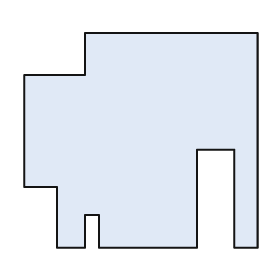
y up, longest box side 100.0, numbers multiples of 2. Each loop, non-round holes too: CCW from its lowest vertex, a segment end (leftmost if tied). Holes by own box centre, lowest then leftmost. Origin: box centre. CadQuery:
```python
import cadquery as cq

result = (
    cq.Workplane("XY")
    .moveTo(-36.0, -46.0)
    .lineTo(-24.0, -46.0)
    .lineTo(-24.0, -32.0)
    .lineTo(-18.0, -32.0)
    .lineTo(-18.0, -46.0)
    .lineTo(24.0, -46.0)
    .lineTo(24.0, -4.0)
    .lineTo(40.0, -4.0)
    .lineTo(40.0, -46.0)
    .lineTo(50.0, -46.0)
    .lineTo(50.0, 46.0)
    .lineTo(-24.0, 46.0)
    .lineTo(-24.0, 28.0)
    .lineTo(-50.0, 28.0)
    .lineTo(-50.0, -20.0)
    .lineTo(-36.0, -20.0)
    .close()
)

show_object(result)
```